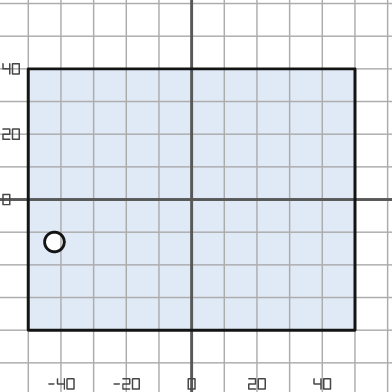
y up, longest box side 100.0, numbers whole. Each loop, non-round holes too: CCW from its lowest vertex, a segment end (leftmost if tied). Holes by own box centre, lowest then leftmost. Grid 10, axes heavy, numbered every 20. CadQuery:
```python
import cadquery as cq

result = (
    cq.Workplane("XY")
    .moveTo(-50.0, -40.0)
    .lineTo(50.0, -40.0)
    .lineTo(50.0, 40.0)
    .lineTo(-50.0, 40.0)
    .close()
    .moveTo(-42.0, -13.0)
    .circle(3.0)
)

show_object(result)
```